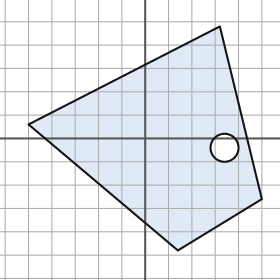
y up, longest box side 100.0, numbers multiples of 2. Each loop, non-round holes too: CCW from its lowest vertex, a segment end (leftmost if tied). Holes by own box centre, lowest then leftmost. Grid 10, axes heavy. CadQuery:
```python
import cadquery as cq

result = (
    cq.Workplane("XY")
    .moveTo(14.0, -48.0)
    .lineTo(50.0, -26.0)
    .lineTo(32.0, 48.0)
    .lineTo(-50.0, 6.0)
    .close()
    .moveTo(34.0, -4.0)
    .circle(6.0)
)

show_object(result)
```